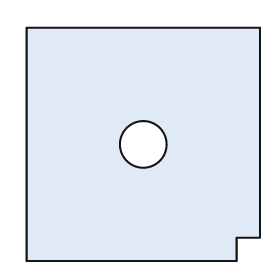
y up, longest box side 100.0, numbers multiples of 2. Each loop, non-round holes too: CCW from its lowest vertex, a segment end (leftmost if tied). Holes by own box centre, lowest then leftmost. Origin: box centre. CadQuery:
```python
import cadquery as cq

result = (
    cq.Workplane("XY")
    .moveTo(-50.0, -50.0)
    .lineTo(40.0, -50.0)
    .lineTo(40.0, -40.0)
    .lineTo(50.0, -40.0)
    .lineTo(50.0, 50.0)
    .lineTo(-50.0, 50.0)
    .close()
    .moveTo(0.0, 0.0)
    .circle(10.0)
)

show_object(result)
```